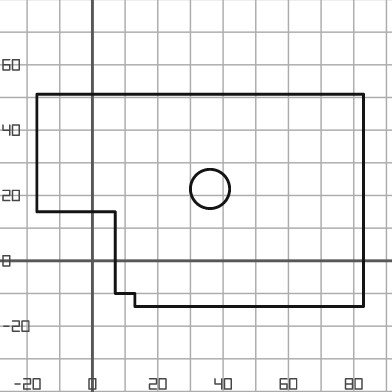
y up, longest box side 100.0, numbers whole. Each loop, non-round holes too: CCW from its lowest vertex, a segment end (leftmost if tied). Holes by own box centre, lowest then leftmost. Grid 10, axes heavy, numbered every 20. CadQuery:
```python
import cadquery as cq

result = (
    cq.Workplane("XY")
    .moveTo(13.0, -14.0)
    .lineTo(83.0, -14.0)
    .lineTo(83.0, 51.0)
    .lineTo(-17.0, 51.0)
    .lineTo(-17.0, 15.0)
    .lineTo(7.0, 15.0)
    .lineTo(7.0, -10.0)
    .lineTo(13.0, -10.0)
    .close()
    .moveTo(36.0, 22.0)
    .circle(6.0)
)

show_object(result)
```